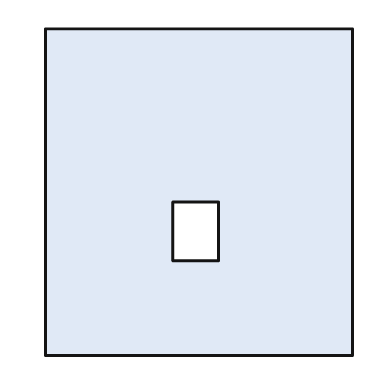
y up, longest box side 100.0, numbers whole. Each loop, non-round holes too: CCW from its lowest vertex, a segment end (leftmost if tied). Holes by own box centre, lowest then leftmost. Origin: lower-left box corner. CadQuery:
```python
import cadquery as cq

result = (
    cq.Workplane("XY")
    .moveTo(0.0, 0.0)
    .lineTo(94.0, 0.0)
    .lineTo(94.0, 100.0)
    .lineTo(0.0, 100.0)
    .close()
    .moveTo(39.0, 29.0)
    .lineTo(53.0, 29.0)
    .lineTo(53.0, 47.0)
    .lineTo(39.0, 47.0)
    .close()
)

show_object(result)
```